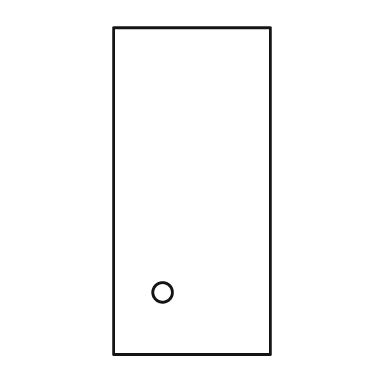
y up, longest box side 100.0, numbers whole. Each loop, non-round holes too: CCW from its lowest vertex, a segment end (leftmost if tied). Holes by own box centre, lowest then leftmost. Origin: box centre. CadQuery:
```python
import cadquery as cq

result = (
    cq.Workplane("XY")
    .moveTo(-24.0, -50.0)
    .lineTo(24.0, -50.0)
    .lineTo(24.0, 50.0)
    .lineTo(-24.0, 50.0)
    .close()
    .moveTo(-9.0, -31.0)
    .circle(3.0)
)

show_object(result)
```